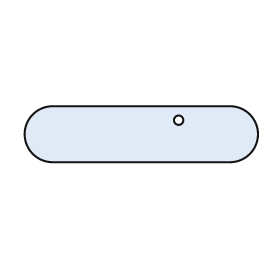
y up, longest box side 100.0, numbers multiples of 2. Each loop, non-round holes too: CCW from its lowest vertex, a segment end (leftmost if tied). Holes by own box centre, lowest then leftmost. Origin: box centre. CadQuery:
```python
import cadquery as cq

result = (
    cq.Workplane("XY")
    .moveTo(-38.0, -12.0)
    .lineTo(38.0, -12.0)
    .threePointArc((50.0, 0.0), (38.0, 12.0))
    .lineTo(-38.0, 12.0)
    .threePointArc((-50.0, 0.0), (-38.0, -12.0))
    .close()
    .moveTo(16.0, 6.0)
    .circle(2.0)
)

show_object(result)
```